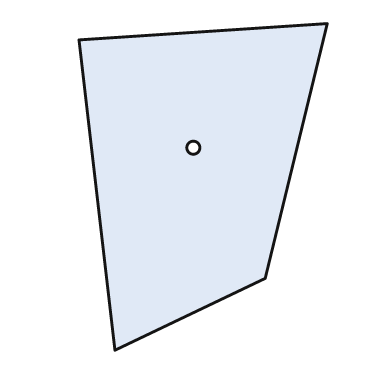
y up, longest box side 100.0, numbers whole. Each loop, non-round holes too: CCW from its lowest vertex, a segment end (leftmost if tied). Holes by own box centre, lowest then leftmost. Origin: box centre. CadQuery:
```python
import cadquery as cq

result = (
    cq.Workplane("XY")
    .moveTo(-27.0, -50.0)
    .lineTo(19.0, -28.0)
    .lineTo(38.0, 50.0)
    .lineTo(-38.0, 45.0)
    .close()
    .moveTo(-3.0, 12.0)
    .circle(2.0)
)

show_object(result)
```